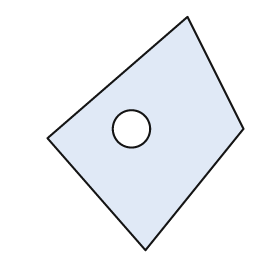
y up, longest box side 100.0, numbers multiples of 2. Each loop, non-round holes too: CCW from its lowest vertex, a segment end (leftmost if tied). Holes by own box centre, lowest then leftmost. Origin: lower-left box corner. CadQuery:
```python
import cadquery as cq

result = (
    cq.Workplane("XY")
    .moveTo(42.0, 0.0)
    .lineTo(84.0, 52.0)
    .lineTo(60.0, 100.0)
    .lineTo(0.0, 48.0)
    .close()
    .moveTo(36.0, 52.0)
    .circle(8.0)
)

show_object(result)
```